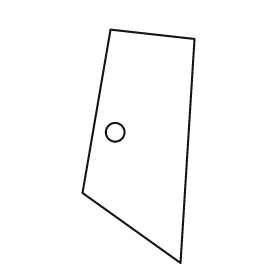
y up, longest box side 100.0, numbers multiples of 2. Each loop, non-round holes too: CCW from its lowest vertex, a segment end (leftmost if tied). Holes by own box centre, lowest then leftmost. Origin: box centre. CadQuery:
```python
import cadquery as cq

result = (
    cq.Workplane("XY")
    .moveTo(18.0, -50.0)
    .lineTo(24.0, 46.0)
    .lineTo(-12.0, 50.0)
    .lineTo(-24.0, -20.0)
    .close()
    .moveTo(-10.0, 6.0)
    .circle(4.0)
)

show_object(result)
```